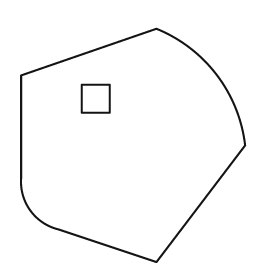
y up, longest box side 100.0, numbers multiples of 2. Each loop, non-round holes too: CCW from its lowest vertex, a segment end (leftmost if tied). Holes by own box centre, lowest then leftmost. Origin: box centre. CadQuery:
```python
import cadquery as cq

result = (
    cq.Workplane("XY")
    .moveTo(10.0, -50.0)
    .lineTo(48.0, 0.0)
    .threePointArc((36.0, 30.0), (10.0, 50.0))
    .lineTo(-48.0, 30.0)
    .lineTo(-48.0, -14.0)
    .threePointArc((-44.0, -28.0), (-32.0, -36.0))
    .close()
    .moveTo(-22.0, 14.0)
    .lineTo(-10.0, 14.0)
    .lineTo(-10.0, 26.0)
    .lineTo(-22.0, 26.0)
    .close()
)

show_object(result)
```